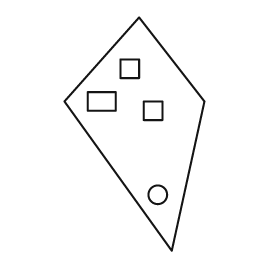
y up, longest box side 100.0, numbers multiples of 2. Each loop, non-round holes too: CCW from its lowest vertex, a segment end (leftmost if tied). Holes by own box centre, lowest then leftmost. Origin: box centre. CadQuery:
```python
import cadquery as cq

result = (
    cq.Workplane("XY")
    .moveTo(16.0, -50.0)
    .lineTo(30.0, 14.0)
    .lineTo(2.0, 50.0)
    .lineTo(-30.0, 14.0)
    .close()
    .moveTo(10.0, -26.0)
    .circle(4.0)
    .moveTo(4.0, 6.0)
    .lineTo(12.0, 6.0)
    .lineTo(12.0, 14.0)
    .lineTo(4.0, 14.0)
    .close()
    .moveTo(-20.0, 10.0)
    .lineTo(-8.0, 10.0)
    .lineTo(-8.0, 18.0)
    .lineTo(-20.0, 18.0)
    .close()
    .moveTo(-6.0, 24.0)
    .lineTo(2.0, 24.0)
    .lineTo(2.0, 32.0)
    .lineTo(-6.0, 32.0)
    .close()
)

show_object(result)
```